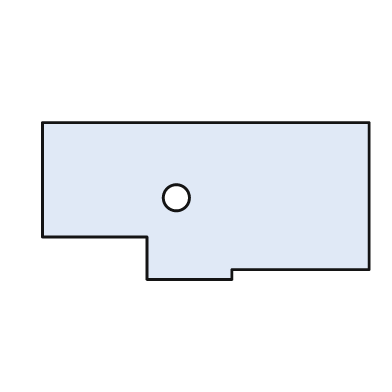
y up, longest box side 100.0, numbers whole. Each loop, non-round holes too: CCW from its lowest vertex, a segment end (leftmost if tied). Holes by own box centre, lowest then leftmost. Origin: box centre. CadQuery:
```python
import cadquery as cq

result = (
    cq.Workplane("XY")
    .moveTo(-18.0, -24.0)
    .lineTo(8.0, -24.0)
    .lineTo(8.0, -21.0)
    .lineTo(50.0, -21.0)
    .lineTo(50.0, 24.0)
    .lineTo(-50.0, 24.0)
    .lineTo(-50.0, -11.0)
    .lineTo(-18.0, -11.0)
    .close()
    .moveTo(-9.0, 1.0)
    .circle(4.0)
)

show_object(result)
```